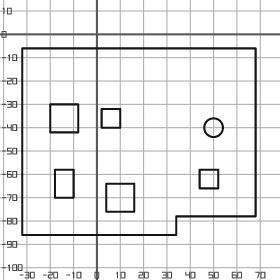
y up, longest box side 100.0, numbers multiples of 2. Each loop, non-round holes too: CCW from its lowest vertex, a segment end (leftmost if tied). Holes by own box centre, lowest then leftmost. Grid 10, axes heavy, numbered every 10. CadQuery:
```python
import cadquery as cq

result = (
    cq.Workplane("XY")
    .moveTo(-32.0, -86.0)
    .lineTo(34.0, -86.0)
    .lineTo(34.0, -78.0)
    .lineTo(68.0, -78.0)
    .lineTo(68.0, -6.0)
    .lineTo(-32.0, -6.0)
    .close()
    .moveTo(4.0, -76.0)
    .lineTo(16.0, -76.0)
    .lineTo(16.0, -64.0)
    .lineTo(4.0, -64.0)
    .close()
    .moveTo(-18.0, -70.0)
    .lineTo(-10.0, -70.0)
    .lineTo(-10.0, -58.0)
    .lineTo(-18.0, -58.0)
    .close()
    .moveTo(44.0, -66.0)
    .lineTo(52.0, -66.0)
    .lineTo(52.0, -58.0)
    .lineTo(44.0, -58.0)
    .close()
    .moveTo(50.0, -40.0)
    .circle(4.0)
    .moveTo(-20.0, -42.0)
    .lineTo(-8.0, -42.0)
    .lineTo(-8.0, -30.0)
    .lineTo(-20.0, -30.0)
    .close()
    .moveTo(2.0, -40.0)
    .lineTo(10.0, -40.0)
    .lineTo(10.0, -32.0)
    .lineTo(2.0, -32.0)
    .close()
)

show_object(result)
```